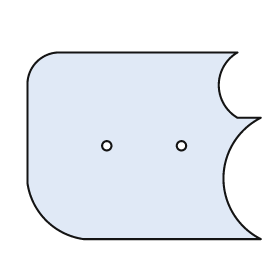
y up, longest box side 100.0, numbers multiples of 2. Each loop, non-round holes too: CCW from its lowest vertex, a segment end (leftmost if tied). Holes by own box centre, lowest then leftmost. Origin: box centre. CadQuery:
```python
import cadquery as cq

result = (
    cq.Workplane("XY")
    .moveTo(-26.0, -40.0)
    .lineTo(50.0, -40.0)
    .threePointArc((34.0, -14.0), (50.0, 12.0))
    .lineTo(40.0, 12.0)
    .threePointArc((32.0, 26.0), (40.0, 40.0))
    .lineTo(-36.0, 40.0)
    .threePointArc((-46.0, 36.0), (-50.0, 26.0))
    .lineTo(-50.0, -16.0)
    .threePointArc((-42.0, -32.0), (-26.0, -40.0))
    .close()
    .moveTo(-16.0, 0.0)
    .circle(2.0)
    .moveTo(16.0, 0.0)
    .circle(2.0)
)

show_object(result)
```